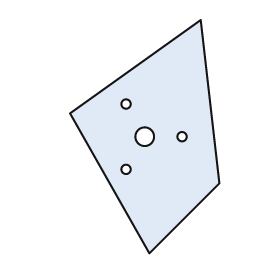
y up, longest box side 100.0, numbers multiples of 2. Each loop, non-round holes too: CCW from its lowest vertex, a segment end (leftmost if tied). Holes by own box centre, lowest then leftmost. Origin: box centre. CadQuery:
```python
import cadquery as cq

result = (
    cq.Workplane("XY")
    .moveTo(2.0, -50.0)
    .lineTo(32.0, -20.0)
    .lineTo(24.0, 50.0)
    .lineTo(-32.0, 10.0)
    .close()
    .moveTo(-8.0, -14.0)
    .circle(2.0)
    .moveTo(0.0, 0.0)
    .circle(4.0)
    .moveTo(16.0, 0.0)
    .circle(2.0)
    .moveTo(-8.0, 14.0)
    .circle(2.0)
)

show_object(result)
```